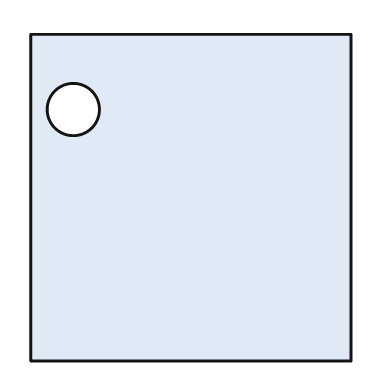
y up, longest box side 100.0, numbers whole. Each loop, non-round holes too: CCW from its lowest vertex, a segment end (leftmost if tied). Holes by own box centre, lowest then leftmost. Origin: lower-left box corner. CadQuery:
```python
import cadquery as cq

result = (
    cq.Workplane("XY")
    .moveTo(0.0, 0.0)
    .lineTo(98.0, 0.0)
    .lineTo(98.0, 100.0)
    .lineTo(0.0, 100.0)
    .close()
    .moveTo(13.0, 77.0)
    .circle(8.0)
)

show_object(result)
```